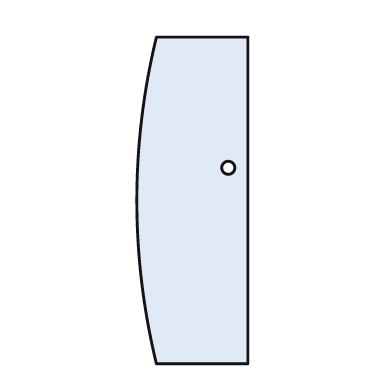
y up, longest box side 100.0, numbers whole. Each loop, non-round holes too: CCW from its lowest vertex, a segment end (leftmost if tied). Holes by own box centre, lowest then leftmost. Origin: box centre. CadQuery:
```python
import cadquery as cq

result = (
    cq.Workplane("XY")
    .moveTo(-11.0, -50.0)
    .lineTo(17.0, -50.0)
    .lineTo(17.0, 50.0)
    .lineTo(-11.0, 50.0)
    .threePointArc((-17.0, 0.0), (-11.0, -50.0))
    .close()
    .moveTo(11.0, 10.0)
    .circle(2.0)
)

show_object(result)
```